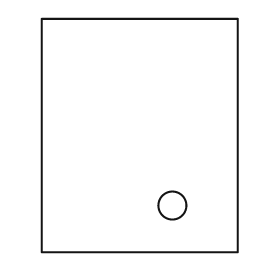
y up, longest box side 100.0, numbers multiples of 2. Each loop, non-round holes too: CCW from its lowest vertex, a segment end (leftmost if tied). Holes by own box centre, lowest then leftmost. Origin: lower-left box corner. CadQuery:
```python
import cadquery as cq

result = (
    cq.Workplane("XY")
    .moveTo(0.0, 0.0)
    .lineTo(84.0, 0.0)
    .lineTo(84.0, 100.0)
    .lineTo(0.0, 100.0)
    .close()
    .moveTo(56.0, 20.0)
    .circle(6.0)
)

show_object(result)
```